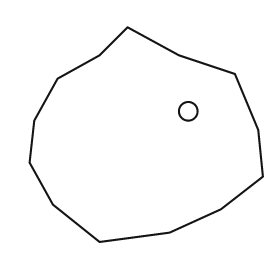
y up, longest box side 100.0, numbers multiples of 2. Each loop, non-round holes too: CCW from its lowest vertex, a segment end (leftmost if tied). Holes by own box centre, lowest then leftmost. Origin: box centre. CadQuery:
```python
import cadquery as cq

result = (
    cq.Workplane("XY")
    .moveTo(-20.0, -46.0)
    .lineTo(10.0, -42.0)
    .lineTo(32.0, -32.0)
    .lineTo(50.0, -18.0)
    .lineTo(48.0, 2.0)
    .lineTo(38.0, 26.0)
    .lineTo(14.0, 34.0)
    .lineTo(-8.0, 46.0)
    .lineTo(-20.0, 34.0)
    .lineTo(-38.0, 24.0)
    .lineTo(-48.0, 6.0)
    .lineTo(-50.0, -12.0)
    .lineTo(-40.0, -30.0)
    .close()
    .moveTo(18.0, 10.0)
    .circle(4.0)
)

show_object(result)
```